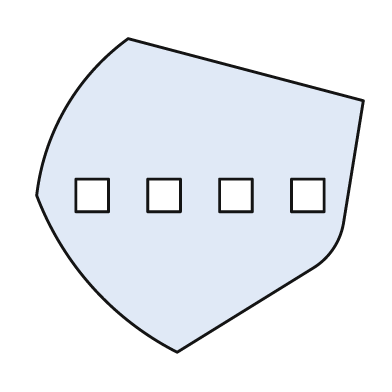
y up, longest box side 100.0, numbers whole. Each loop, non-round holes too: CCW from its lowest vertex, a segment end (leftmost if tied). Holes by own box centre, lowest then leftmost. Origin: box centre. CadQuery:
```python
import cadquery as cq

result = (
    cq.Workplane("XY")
    .moveTo(-7.0, -48.0)
    .lineTo(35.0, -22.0)
    .threePointArc((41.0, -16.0), (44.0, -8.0))
    .lineTo(50.0, 29.0)
    .lineTo(-22.0, 48.0)
    .threePointArc((-41.0, 27.0), (-50.0, 0.0))
    .threePointArc((-33.0, -28.0), (-7.0, -48.0))
    .close()
    .moveTo(-38.0, -5.0)
    .lineTo(-28.0, -5.0)
    .lineTo(-28.0, 5.0)
    .lineTo(-38.0, 5.0)
    .close()
    .moveTo(-16.0, -5.0)
    .lineTo(-6.0, -5.0)
    .lineTo(-6.0, 5.0)
    .lineTo(-16.0, 5.0)
    .close()
    .moveTo(6.0, -5.0)
    .lineTo(16.0, -5.0)
    .lineTo(16.0, 5.0)
    .lineTo(6.0, 5.0)
    .close()
    .moveTo(28.0, -5.0)
    .lineTo(38.0, -5.0)
    .lineTo(38.0, 5.0)
    .lineTo(28.0, 5.0)
    .close()
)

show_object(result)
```